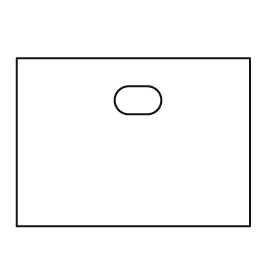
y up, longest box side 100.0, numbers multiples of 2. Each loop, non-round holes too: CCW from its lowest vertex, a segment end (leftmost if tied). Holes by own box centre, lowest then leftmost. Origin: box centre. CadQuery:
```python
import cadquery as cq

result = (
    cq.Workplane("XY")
    .moveTo(-50.0, -36.0)
    .lineTo(50.0, -36.0)
    .lineTo(50.0, 36.0)
    .lineTo(-50.0, 36.0)
    .close()
    .moveTo(-2.0, 12.0)
    .lineTo(6.0, 12.0)
    .threePointArc((12.0, 18.0), (6.0, 24.0))
    .lineTo(-2.0, 24.0)
    .threePointArc((-8.0, 18.0), (-2.0, 12.0))
    .close()
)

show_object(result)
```